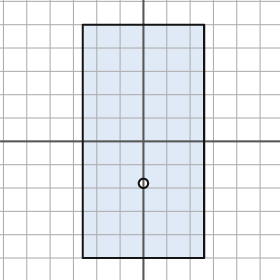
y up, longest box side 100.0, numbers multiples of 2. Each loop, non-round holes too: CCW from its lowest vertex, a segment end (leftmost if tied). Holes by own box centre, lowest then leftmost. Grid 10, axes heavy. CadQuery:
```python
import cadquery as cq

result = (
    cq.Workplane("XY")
    .moveTo(-26.0, -50.0)
    .lineTo(26.0, -50.0)
    .lineTo(26.0, 50.0)
    .lineTo(-26.0, 50.0)
    .close()
    .moveTo(0.0, -18.0)
    .circle(2.0)
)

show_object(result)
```